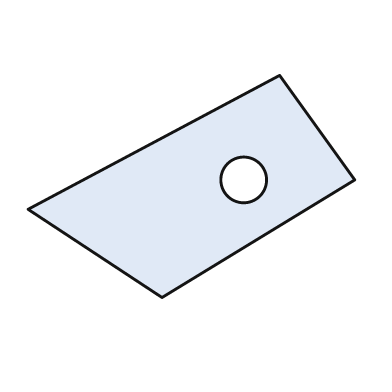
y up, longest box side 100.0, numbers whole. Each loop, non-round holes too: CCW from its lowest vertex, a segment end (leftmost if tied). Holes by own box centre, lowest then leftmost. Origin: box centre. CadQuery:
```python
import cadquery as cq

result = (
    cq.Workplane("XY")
    .moveTo(-9.0, -34.0)
    .lineTo(50.0, 2.0)
    .lineTo(27.0, 34.0)
    .lineTo(-50.0, -7.0)
    .close()
    .moveTo(16.0, 2.0)
    .circle(7.0)
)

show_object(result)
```